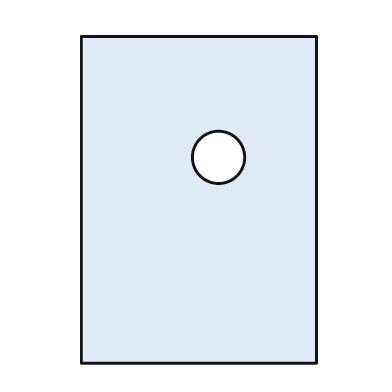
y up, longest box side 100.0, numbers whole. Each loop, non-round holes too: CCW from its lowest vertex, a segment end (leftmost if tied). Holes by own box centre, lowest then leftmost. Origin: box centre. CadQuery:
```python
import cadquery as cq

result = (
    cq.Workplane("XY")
    .moveTo(-36.0, -50.0)
    .lineTo(36.0, -50.0)
    .lineTo(36.0, 50.0)
    .lineTo(-36.0, 50.0)
    .close()
    .moveTo(6.0, 13.0)
    .circle(8.0)
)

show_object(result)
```